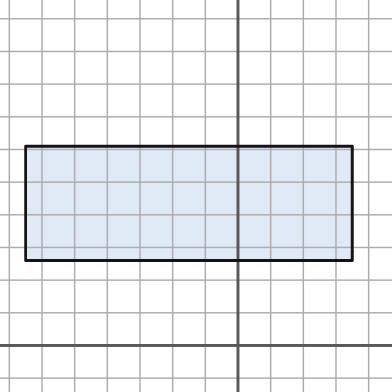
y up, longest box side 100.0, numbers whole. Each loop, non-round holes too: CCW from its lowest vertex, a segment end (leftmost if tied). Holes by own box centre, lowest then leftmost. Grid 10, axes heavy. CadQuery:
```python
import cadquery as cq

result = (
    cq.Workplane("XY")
    .moveTo(-65.0, 26.0)
    .lineTo(35.0, 26.0)
    .lineTo(35.0, 61.0)
    .lineTo(-65.0, 61.0)
    .close()
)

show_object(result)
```